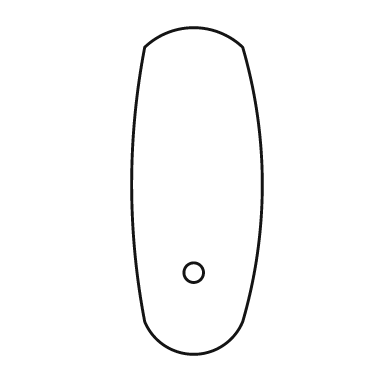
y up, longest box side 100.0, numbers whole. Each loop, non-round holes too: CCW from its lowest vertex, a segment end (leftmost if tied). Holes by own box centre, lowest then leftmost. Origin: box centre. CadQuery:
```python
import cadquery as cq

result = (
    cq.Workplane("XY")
    .moveTo(-16.0, -40.0)
    .threePointArc((-1.0, -50.0), (14.0, -40.0))
    .threePointArc((20.0, 2.0), (14.0, 44.0))
    .threePointArc((-1.0, 50.0), (-16.0, 44.0))
    .threePointArc((-20.0, 2.0), (-16.0, -40.0))
    .close()
    .moveTo(-1.0, -25.0)
    .circle(3.0)
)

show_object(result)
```